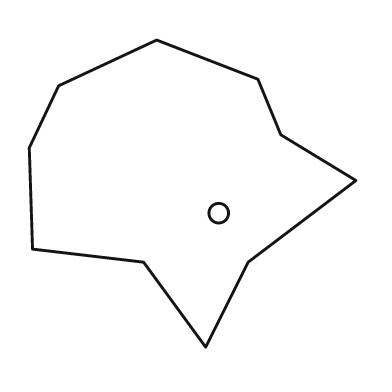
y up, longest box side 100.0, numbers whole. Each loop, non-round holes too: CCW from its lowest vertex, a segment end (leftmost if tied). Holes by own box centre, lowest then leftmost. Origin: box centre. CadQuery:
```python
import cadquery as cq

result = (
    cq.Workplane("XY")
    .moveTo(4.0, -47.0)
    .lineTo(17.0, -21.0)
    .lineTo(50.0, 4.0)
    .lineTo(27.0, 18.0)
    .lineTo(20.0, 35.0)
    .lineTo(-11.0, 47.0)
    .lineTo(-41.0, 33.0)
    .lineTo(-50.0, 14.0)
    .lineTo(-49.0, -17.0)
    .lineTo(-15.0, -21.0)
    .close()
    .moveTo(8.0, -6.0)
    .circle(3.0)
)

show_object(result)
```